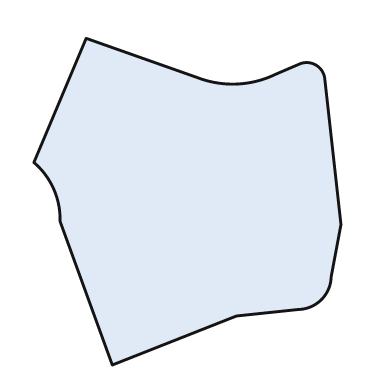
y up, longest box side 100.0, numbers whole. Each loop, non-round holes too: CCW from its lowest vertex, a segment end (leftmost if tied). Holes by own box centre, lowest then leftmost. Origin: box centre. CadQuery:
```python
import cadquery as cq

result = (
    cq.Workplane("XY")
    .moveTo(-23.0, -50.0)
    .lineTo(15.0, -35.0)
    .lineTo(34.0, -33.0)
    .threePointArc((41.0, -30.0), (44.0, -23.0))
    .lineTo(47.0, -7.0)
    .lineTo(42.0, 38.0)
    .threePointArc((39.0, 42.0), (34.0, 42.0))
    .lineTo(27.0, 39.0)
    .threePointArc((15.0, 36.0), (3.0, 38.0))
    .lineTo(-31.0, 50.0)
    .lineTo(-47.0, 12.0)
    .threePointArc((-41.0, 4.0), (-39.0, -6.0))
    .close()
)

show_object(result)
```